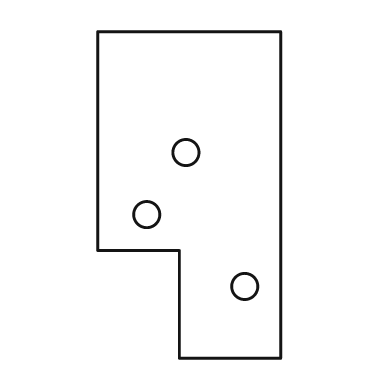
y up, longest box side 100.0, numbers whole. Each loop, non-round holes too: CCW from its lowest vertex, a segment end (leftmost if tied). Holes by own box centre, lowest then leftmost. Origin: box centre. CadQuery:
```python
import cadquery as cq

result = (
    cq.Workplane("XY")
    .moveTo(-3.0, -50.0)
    .lineTo(28.0, -50.0)
    .lineTo(28.0, 50.0)
    .lineTo(-28.0, 50.0)
    .lineTo(-28.0, -17.0)
    .lineTo(-3.0, -17.0)
    .close()
    .moveTo(17.0, -28.0)
    .circle(4.0)
    .moveTo(-13.0, -6.0)
    .circle(4.0)
    .moveTo(-1.0, 13.0)
    .circle(4.0)
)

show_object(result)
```